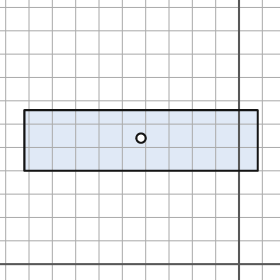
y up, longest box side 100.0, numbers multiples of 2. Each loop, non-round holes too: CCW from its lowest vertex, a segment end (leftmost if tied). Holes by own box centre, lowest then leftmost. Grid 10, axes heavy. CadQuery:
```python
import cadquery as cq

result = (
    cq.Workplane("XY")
    .moveTo(-92.0, 40.0)
    .lineTo(8.0, 40.0)
    .lineTo(8.0, 66.0)
    .lineTo(-92.0, 66.0)
    .close()
    .moveTo(-42.0, 54.0)
    .circle(2.0)
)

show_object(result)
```